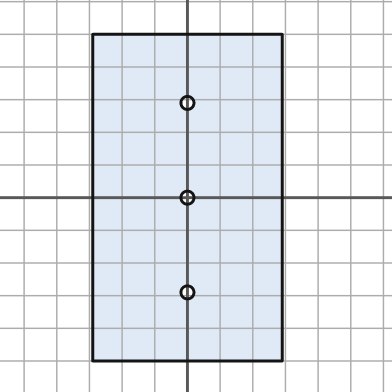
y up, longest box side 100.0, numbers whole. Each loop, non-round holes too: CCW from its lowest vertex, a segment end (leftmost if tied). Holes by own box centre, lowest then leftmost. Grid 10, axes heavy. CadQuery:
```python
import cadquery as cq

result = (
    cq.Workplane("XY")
    .moveTo(-29.0, -50.0)
    .lineTo(29.0, -50.0)
    .lineTo(29.0, 50.0)
    .lineTo(-29.0, 50.0)
    .close()
    .moveTo(0.0, -29.0)
    .circle(2.0)
    .moveTo(0.0, 0.0)
    .circle(2.0)
    .moveTo(0.0, 29.0)
    .circle(2.0)
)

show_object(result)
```